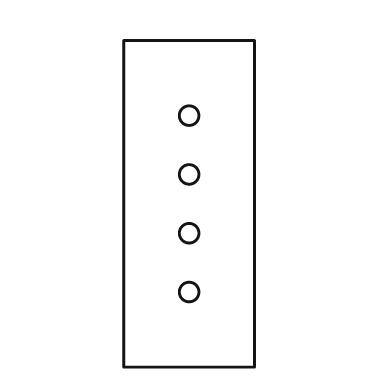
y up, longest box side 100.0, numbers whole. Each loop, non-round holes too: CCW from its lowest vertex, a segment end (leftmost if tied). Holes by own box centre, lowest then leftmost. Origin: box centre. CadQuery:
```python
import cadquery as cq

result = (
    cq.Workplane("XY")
    .moveTo(-20.0, -50.0)
    .lineTo(20.0, -50.0)
    .lineTo(20.0, 50.0)
    .lineTo(-20.0, 50.0)
    .close()
    .moveTo(0.0, -27.0)
    .circle(3.0)
    .moveTo(0.0, -9.0)
    .circle(3.0)
    .moveTo(0.0, 9.0)
    .circle(3.0)
    .moveTo(0.0, 27.0)
    .circle(3.0)
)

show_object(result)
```